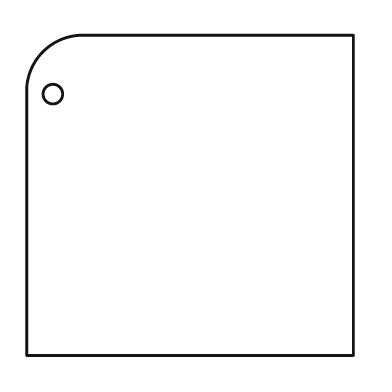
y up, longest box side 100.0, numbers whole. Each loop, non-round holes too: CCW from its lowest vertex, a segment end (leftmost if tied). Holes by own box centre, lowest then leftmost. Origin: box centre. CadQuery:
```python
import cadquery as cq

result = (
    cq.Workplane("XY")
    .moveTo(-50.0, -49.0)
    .lineTo(50.0, -49.0)
    .lineTo(50.0, 49.0)
    .lineTo(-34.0, 49.0)
    .threePointArc((-45.0, 44.0), (-50.0, 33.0))
    .close()
    .moveTo(-42.0, 31.0)
    .circle(3.0)
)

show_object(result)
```